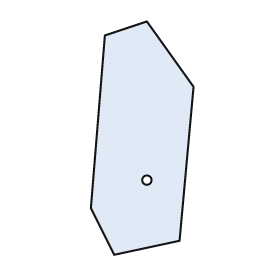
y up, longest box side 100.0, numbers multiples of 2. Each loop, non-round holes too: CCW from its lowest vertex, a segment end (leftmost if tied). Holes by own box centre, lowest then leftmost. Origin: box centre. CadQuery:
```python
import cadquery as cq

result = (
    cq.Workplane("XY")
    .moveTo(-12.0, -50.0)
    .lineTo(16.0, -44.0)
    .lineTo(22.0, 22.0)
    .lineTo(2.0, 50.0)
    .lineTo(-16.0, 44.0)
    .lineTo(-22.0, -30.0)
    .close()
    .moveTo(2.0, -18.0)
    .circle(2.0)
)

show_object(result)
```